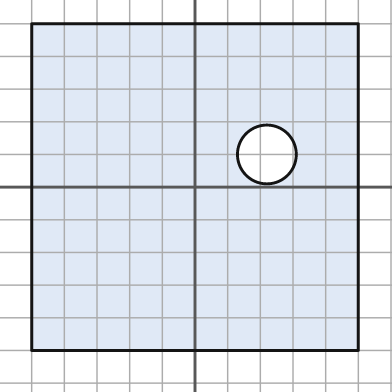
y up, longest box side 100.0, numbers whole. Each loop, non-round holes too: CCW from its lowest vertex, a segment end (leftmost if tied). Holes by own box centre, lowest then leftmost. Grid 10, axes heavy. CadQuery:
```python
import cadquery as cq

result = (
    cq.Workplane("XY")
    .moveTo(-50.0, -50.0)
    .lineTo(50.0, -50.0)
    .lineTo(50.0, 50.0)
    .lineTo(-50.0, 50.0)
    .close()
    .moveTo(22.0, 10.0)
    .circle(9.0)
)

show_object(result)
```